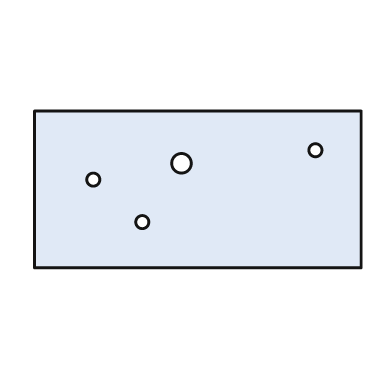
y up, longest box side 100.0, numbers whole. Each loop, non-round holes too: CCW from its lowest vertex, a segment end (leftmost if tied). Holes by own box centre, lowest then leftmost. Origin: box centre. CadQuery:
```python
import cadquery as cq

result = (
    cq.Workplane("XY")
    .moveTo(-50.0, -24.0)
    .lineTo(50.0, -24.0)
    .lineTo(50.0, 24.0)
    .lineTo(-50.0, 24.0)
    .close()
    .moveTo(-17.0, -10.0)
    .circle(2.0)
    .moveTo(-32.0, 3.0)
    .circle(2.0)
    .moveTo(-5.0, 8.0)
    .circle(3.0)
    .moveTo(36.0, 12.0)
    .circle(2.0)
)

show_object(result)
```